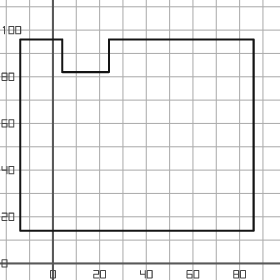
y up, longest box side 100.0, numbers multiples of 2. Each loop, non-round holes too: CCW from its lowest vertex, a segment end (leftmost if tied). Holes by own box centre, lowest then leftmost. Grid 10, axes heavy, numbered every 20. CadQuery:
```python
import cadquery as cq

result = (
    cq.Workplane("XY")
    .moveTo(-14.0, 14.0)
    .lineTo(86.0, 14.0)
    .lineTo(86.0, 96.0)
    .lineTo(24.0, 96.0)
    .lineTo(24.0, 82.0)
    .lineTo(4.0, 82.0)
    .lineTo(4.0, 96.0)
    .lineTo(-14.0, 96.0)
    .close()
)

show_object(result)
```